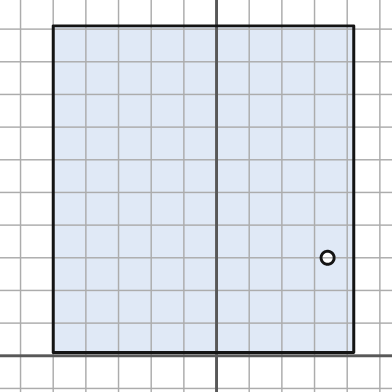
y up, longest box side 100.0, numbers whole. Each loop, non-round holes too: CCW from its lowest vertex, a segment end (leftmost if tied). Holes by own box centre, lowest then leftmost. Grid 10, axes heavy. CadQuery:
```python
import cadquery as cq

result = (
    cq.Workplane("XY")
    .moveTo(-50.0, 1.0)
    .lineTo(42.0, 1.0)
    .lineTo(42.0, 101.0)
    .lineTo(-50.0, 101.0)
    .close()
    .moveTo(34.0, 30.0)
    .circle(2.0)
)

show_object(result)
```